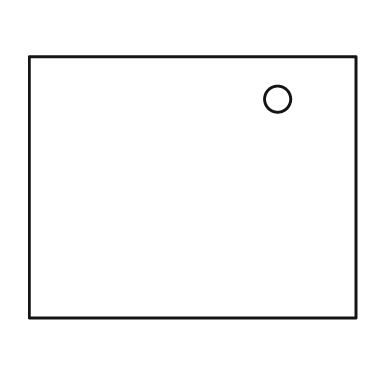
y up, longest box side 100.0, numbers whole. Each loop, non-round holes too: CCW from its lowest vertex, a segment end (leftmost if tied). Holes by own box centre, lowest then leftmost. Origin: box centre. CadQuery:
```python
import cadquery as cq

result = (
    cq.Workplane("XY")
    .moveTo(-50.0, -40.0)
    .lineTo(50.0, -40.0)
    .lineTo(50.0, 40.0)
    .lineTo(-50.0, 40.0)
    .close()
    .moveTo(26.0, 27.0)
    .circle(4.0)
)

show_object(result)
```